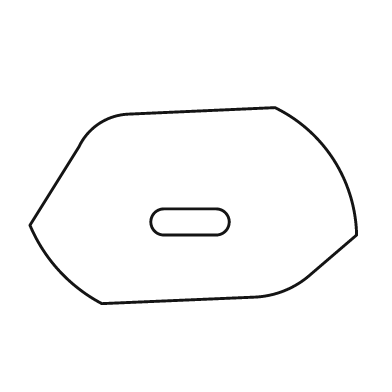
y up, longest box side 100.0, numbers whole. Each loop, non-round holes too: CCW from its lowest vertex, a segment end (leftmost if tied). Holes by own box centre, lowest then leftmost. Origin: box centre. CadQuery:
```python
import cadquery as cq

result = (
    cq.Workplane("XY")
    .moveTo(-28.0, -30.0)
    .lineTo(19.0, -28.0)
    .threePointArc((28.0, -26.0), (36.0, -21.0))
    .lineTo(50.0, -9.0)
    .threePointArc((43.0, 14.0), (25.0, 30.0))
    .lineTo(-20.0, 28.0)
    .threePointArc((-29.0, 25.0), (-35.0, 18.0))
    .lineTo(-50.0, -6.0)
    .threePointArc((-41.0, -20.0), (-28.0, -30.0))
    .close()
    .moveTo(-9.0, -9.0)
    .lineTo(7.0, -9.0)
    .threePointArc((11.0, -5.0), (7.0, -1.0))
    .lineTo(-9.0, -1.0)
    .threePointArc((-13.0, -5.0), (-9.0, -9.0))
    .close()
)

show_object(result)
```